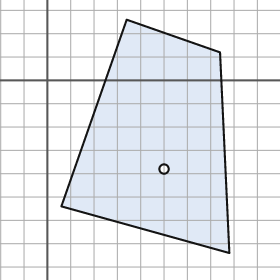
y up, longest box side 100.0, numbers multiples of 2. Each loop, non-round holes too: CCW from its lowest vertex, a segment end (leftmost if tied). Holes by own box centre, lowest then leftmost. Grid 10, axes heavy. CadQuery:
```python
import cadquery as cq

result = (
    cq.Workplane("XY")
    .moveTo(78.0, -74.0)
    .lineTo(74.0, 12.0)
    .lineTo(34.0, 26.0)
    .lineTo(6.0, -54.0)
    .close()
    .moveTo(50.0, -38.0)
    .circle(2.0)
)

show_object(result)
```